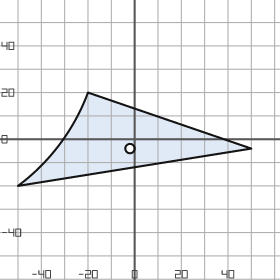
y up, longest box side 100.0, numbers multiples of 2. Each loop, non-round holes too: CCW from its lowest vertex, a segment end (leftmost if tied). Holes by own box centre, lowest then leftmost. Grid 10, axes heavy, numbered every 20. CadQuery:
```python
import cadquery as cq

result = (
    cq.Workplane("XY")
    .moveTo(-50.0, -20.0)
    .lineTo(50.0, -4.0)
    .lineTo(-20.0, 20.0)
    .threePointArc((-32.0, -2.0), (-50.0, -20.0))
    .close()
    .moveTo(-2.0, -4.0)
    .circle(2.0)
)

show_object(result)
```